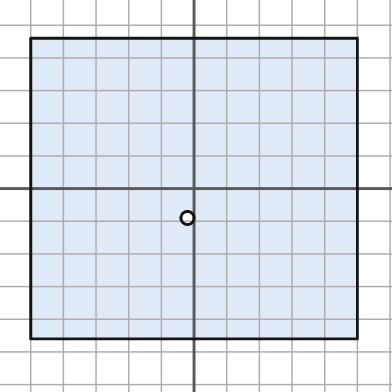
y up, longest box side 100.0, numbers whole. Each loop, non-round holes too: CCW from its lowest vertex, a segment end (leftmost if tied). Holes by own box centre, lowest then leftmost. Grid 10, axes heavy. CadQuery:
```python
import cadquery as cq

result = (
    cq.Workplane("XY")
    .moveTo(-50.0, -46.0)
    .lineTo(50.0, -46.0)
    .lineTo(50.0, 46.0)
    .lineTo(-50.0, 46.0)
    .close()
    .moveTo(-2.0, -9.0)
    .circle(2.0)
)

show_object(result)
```